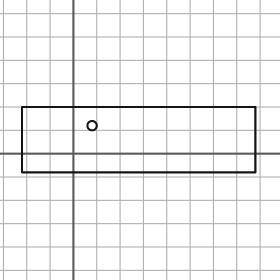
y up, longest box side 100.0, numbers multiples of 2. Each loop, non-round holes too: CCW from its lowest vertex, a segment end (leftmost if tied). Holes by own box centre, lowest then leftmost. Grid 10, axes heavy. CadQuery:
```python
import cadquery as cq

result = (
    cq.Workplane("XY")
    .moveTo(-22.0, -8.0)
    .lineTo(78.0, -8.0)
    .lineTo(78.0, 20.0)
    .lineTo(-22.0, 20.0)
    .close()
    .moveTo(8.0, 12.0)
    .circle(2.0)
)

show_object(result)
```